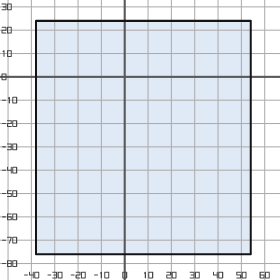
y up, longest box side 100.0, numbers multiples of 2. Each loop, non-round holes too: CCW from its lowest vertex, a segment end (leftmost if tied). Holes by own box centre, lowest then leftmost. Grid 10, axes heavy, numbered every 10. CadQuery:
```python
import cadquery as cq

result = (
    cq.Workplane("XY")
    .moveTo(-38.0, -76.0)
    .lineTo(54.0, -76.0)
    .lineTo(54.0, 24.0)
    .lineTo(-38.0, 24.0)
    .close()
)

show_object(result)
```